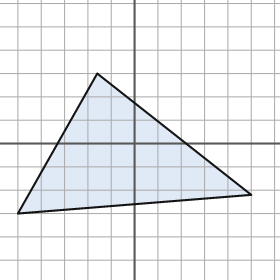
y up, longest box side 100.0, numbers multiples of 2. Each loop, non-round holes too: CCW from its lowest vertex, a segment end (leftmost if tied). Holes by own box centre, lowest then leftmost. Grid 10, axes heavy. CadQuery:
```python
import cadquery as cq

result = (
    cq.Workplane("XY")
    .moveTo(-50.0, -30.0)
    .lineTo(50.0, -22.0)
    .lineTo(-16.0, 30.0)
    .close()
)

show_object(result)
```